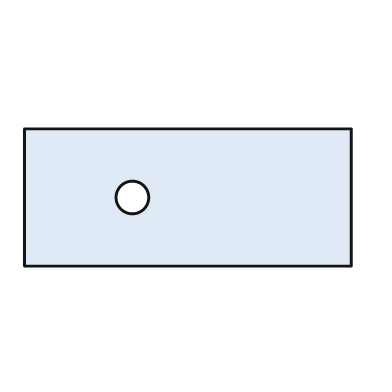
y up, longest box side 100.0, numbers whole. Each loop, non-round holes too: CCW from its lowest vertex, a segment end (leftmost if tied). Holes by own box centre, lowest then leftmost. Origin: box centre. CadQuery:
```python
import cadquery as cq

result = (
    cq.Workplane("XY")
    .moveTo(-50.0, -21.0)
    .lineTo(50.0, -21.0)
    .lineTo(50.0, 21.0)
    .lineTo(-50.0, 21.0)
    .close()
    .moveTo(-17.0, 0.0)
    .circle(5.0)
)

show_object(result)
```